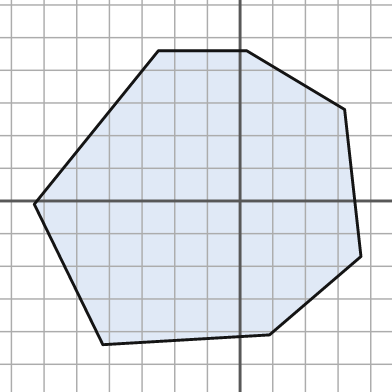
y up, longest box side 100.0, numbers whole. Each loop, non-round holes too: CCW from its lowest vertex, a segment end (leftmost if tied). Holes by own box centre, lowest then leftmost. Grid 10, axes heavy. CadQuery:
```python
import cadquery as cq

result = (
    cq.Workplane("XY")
    .moveTo(-42.0, -44.0)
    .lineTo(9.0, -41.0)
    .lineTo(37.0, -17.0)
    .lineTo(32.0, 28.0)
    .lineTo(2.0, 46.0)
    .lineTo(-25.0, 46.0)
    .lineTo(-63.0, -1.0)
    .close()
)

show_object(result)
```